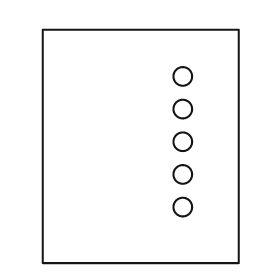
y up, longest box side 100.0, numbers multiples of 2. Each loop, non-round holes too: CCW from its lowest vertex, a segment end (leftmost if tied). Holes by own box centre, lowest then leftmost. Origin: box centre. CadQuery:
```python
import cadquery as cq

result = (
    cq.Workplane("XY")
    .moveTo(-42.0, -50.0)
    .lineTo(42.0, -50.0)
    .lineTo(42.0, 50.0)
    .lineTo(-42.0, 50.0)
    .close()
    .moveTo(18.0, -26.0)
    .circle(4.0)
    .moveTo(18.0, -12.0)
    .circle(4.0)
    .moveTo(18.0, 2.0)
    .circle(4.0)
    .moveTo(18.0, 16.0)
    .circle(4.0)
    .moveTo(18.0, 30.0)
    .circle(4.0)
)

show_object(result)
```